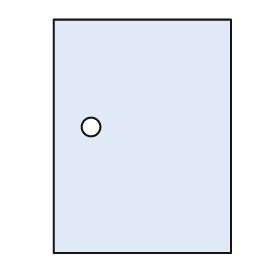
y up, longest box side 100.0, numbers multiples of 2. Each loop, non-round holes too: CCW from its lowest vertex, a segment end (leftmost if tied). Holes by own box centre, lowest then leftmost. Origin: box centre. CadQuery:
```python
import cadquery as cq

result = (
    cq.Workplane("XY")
    .moveTo(-38.0, -50.0)
    .lineTo(38.0, -50.0)
    .lineTo(38.0, 50.0)
    .lineTo(-38.0, 50.0)
    .close()
    .moveTo(-22.0, 4.0)
    .circle(4.0)
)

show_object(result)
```